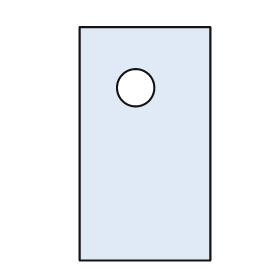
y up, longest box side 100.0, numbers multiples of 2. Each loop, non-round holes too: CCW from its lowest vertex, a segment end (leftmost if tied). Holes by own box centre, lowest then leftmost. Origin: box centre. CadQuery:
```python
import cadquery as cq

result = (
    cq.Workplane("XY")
    .moveTo(-28.0, -50.0)
    .lineTo(28.0, -50.0)
    .lineTo(28.0, 50.0)
    .lineTo(-28.0, 50.0)
    .close()
    .moveTo(-4.0, 24.0)
    .circle(8.0)
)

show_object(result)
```